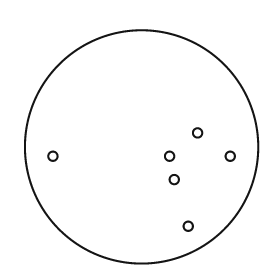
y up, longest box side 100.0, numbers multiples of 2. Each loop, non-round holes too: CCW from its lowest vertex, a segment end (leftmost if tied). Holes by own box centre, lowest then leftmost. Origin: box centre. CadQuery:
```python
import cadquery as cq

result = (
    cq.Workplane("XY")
    .moveTo(0.0, 0.0)
    .circle(50.0)
    .moveTo(20.0, -34.0)
    .circle(2.0)
    .moveTo(14.0, -14.0)
    .circle(2.0)
    .moveTo(-38.0, -4.0)
    .circle(2.0)
    .moveTo(12.0, -4.0)
    .circle(2.0)
    .moveTo(38.0, -4.0)
    .circle(2.0)
    .moveTo(24.0, 6.0)
    .circle(2.0)
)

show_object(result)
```